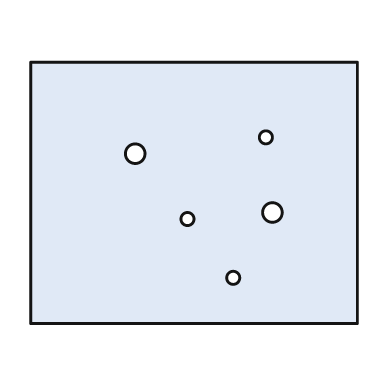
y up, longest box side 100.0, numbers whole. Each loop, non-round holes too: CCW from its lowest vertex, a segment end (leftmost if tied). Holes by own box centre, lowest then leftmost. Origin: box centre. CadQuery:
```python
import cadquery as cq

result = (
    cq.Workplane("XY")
    .moveTo(-50.0, -40.0)
    .lineTo(50.0, -40.0)
    .lineTo(50.0, 40.0)
    .lineTo(-50.0, 40.0)
    .close()
    .moveTo(12.0, -26.0)
    .circle(2.0)
    .moveTo(-2.0, -8.0)
    .circle(2.0)
    .moveTo(24.0, -6.0)
    .circle(3.0)
    .moveTo(-18.0, 12.0)
    .circle(3.0)
    .moveTo(22.0, 17.0)
    .circle(2.0)
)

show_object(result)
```